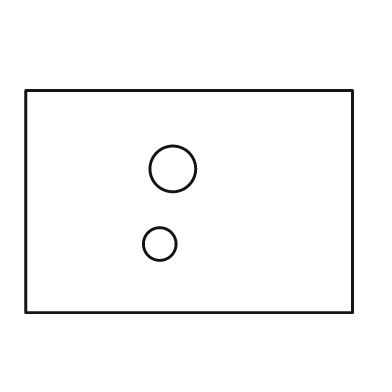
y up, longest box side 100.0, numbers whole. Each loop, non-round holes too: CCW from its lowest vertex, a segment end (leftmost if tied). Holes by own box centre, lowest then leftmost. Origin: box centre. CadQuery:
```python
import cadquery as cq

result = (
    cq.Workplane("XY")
    .moveTo(-50.0, -34.0)
    .lineTo(50.0, -34.0)
    .lineTo(50.0, 34.0)
    .lineTo(-50.0, 34.0)
    .close()
    .moveTo(-9.0, -13.0)
    .circle(5.0)
    .moveTo(-5.0, 10.0)
    .circle(7.0)
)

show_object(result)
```